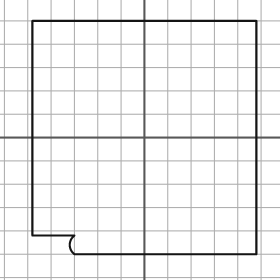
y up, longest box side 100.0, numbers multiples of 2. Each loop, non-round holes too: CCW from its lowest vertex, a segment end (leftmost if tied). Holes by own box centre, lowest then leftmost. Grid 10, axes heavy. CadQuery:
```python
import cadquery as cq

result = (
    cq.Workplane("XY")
    .moveTo(-30.0, -50.0)
    .lineTo(48.0, -50.0)
    .lineTo(48.0, 50.0)
    .lineTo(-48.0, 50.0)
    .lineTo(-48.0, -42.0)
    .lineTo(-30.0, -42.0)
    .threePointArc((-32.0, -46.0), (-30.0, -50.0))
    .close()
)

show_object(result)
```